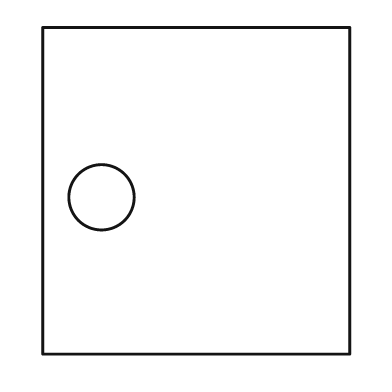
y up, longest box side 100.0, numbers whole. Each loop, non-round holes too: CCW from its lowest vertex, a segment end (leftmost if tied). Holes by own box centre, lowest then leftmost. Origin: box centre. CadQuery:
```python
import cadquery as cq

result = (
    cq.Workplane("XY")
    .moveTo(-47.0, -50.0)
    .lineTo(47.0, -50.0)
    .lineTo(47.0, 50.0)
    .lineTo(-47.0, 50.0)
    .close()
    .moveTo(-29.0, -2.0)
    .circle(10.0)
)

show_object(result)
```